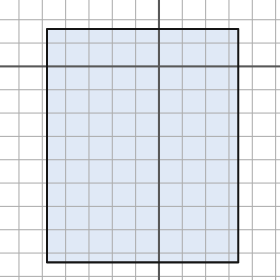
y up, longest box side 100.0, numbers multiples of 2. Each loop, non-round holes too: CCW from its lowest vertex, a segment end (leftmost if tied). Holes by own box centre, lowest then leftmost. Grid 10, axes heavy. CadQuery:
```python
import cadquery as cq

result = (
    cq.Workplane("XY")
    .moveTo(-48.0, -84.0)
    .lineTo(34.0, -84.0)
    .lineTo(34.0, 16.0)
    .lineTo(-48.0, 16.0)
    .close()
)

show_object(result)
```